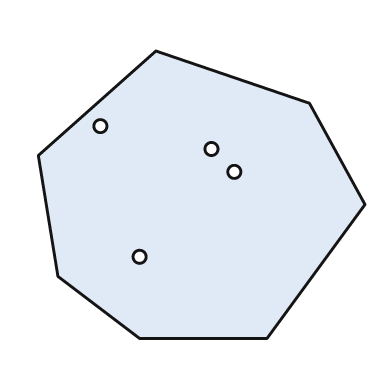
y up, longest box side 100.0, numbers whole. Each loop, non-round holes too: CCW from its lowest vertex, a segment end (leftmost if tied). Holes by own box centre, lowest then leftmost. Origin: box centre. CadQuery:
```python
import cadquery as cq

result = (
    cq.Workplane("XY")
    .moveTo(-19.0, -44.0)
    .lineTo(20.0, -44.0)
    .lineTo(50.0, -3.0)
    .lineTo(33.0, 28.0)
    .lineTo(-14.0, 44.0)
    .lineTo(-50.0, 12.0)
    .lineTo(-44.0, -25.0)
    .close()
    .moveTo(-19.0, -19.0)
    .circle(2.0)
    .moveTo(10.0, 7.0)
    .circle(2.0)
    .moveTo(3.0, 14.0)
    .circle(2.0)
    .moveTo(-31.0, 21.0)
    .circle(2.0)
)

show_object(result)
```